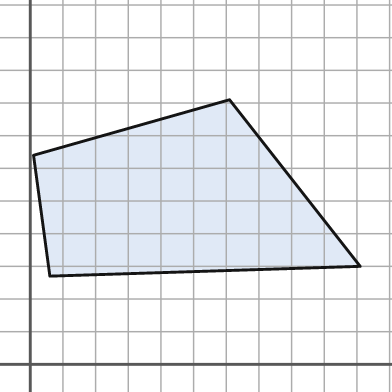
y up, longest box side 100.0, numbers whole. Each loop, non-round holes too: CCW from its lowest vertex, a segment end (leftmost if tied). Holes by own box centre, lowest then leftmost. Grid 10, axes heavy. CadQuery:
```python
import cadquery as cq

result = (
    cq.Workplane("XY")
    .moveTo(6.0, 27.0)
    .lineTo(101.0, 30.0)
    .lineTo(61.0, 81.0)
    .lineTo(1.0, 64.0)
    .close()
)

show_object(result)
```